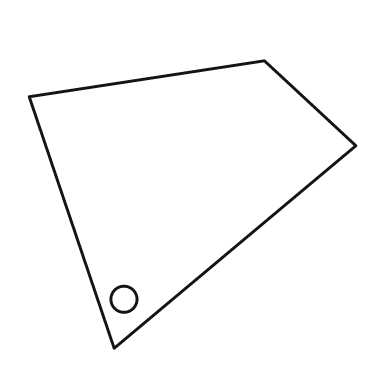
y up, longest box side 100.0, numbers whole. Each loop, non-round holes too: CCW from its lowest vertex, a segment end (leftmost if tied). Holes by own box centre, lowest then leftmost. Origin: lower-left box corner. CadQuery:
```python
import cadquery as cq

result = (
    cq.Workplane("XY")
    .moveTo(26.0, 0.0)
    .lineTo(100.0, 62.0)
    .lineTo(72.0, 88.0)
    .lineTo(0.0, 77.0)
    .close()
    .moveTo(29.0, 15.0)
    .circle(4.0)
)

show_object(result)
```